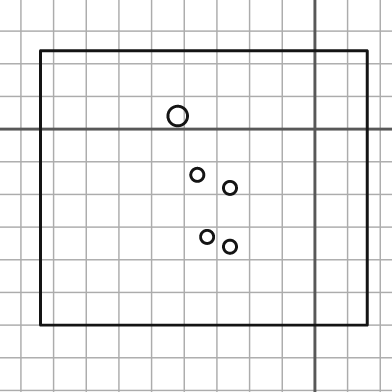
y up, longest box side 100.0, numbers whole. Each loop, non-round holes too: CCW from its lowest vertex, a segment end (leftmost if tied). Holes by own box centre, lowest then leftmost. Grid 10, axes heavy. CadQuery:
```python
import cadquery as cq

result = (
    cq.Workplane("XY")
    .moveTo(-84.0, -60.0)
    .lineTo(16.0, -60.0)
    .lineTo(16.0, 24.0)
    .lineTo(-84.0, 24.0)
    .close()
    .moveTo(-26.0, -36.0)
    .circle(2.0)
    .moveTo(-33.0, -33.0)
    .circle(2.0)
    .moveTo(-26.0, -18.0)
    .circle(2.0)
    .moveTo(-36.0, -14.0)
    .circle(2.0)
    .moveTo(-42.0, 4.0)
    .circle(3.0)
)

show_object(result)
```